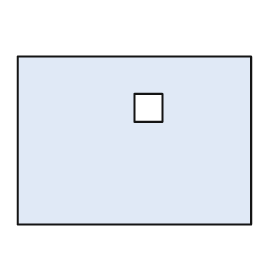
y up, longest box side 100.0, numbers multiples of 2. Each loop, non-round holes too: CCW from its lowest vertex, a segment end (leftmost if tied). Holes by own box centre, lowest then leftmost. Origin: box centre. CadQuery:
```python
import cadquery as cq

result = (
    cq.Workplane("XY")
    .moveTo(-50.0, -36.0)
    .lineTo(50.0, -36.0)
    .lineTo(50.0, 36.0)
    .lineTo(-50.0, 36.0)
    .close()
    .moveTo(0.0, 8.0)
    .lineTo(12.0, 8.0)
    .lineTo(12.0, 20.0)
    .lineTo(0.0, 20.0)
    .close()
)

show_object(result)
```